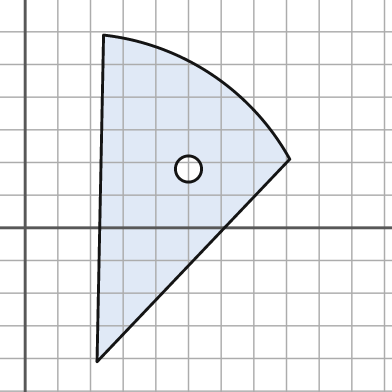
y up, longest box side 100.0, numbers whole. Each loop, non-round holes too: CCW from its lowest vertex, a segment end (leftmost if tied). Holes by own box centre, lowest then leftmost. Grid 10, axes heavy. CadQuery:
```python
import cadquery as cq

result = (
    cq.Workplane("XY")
    .moveTo(22.0, -41.0)
    .lineTo(81.0, 21.0)
    .threePointArc((57.0, 47.0), (24.0, 59.0))
    .close()
    .moveTo(50.0, 18.0)
    .circle(4.0)
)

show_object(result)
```